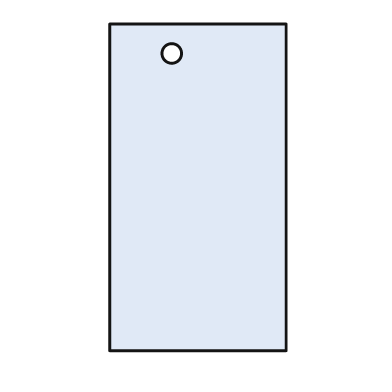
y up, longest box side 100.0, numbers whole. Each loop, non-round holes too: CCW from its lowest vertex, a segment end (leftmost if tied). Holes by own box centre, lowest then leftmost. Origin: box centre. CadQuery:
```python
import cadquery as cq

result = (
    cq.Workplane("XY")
    .moveTo(-27.0, -50.0)
    .lineTo(27.0, -50.0)
    .lineTo(27.0, 50.0)
    .lineTo(-27.0, 50.0)
    .close()
    .moveTo(-8.0, 41.0)
    .circle(3.0)
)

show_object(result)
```